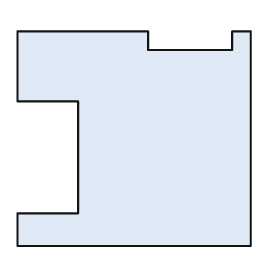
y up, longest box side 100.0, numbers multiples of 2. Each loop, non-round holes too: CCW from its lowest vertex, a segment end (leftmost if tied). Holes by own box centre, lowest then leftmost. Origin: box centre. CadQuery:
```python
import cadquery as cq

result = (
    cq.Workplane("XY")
    .moveTo(-50.0, -46.0)
    .lineTo(50.0, -46.0)
    .lineTo(50.0, 46.0)
    .lineTo(42.0, 46.0)
    .lineTo(42.0, 38.0)
    .lineTo(6.0, 38.0)
    .lineTo(6.0, 46.0)
    .lineTo(-50.0, 46.0)
    .lineTo(-50.0, 16.0)
    .lineTo(-24.0, 16.0)
    .lineTo(-24.0, -32.0)
    .lineTo(-50.0, -32.0)
    .close()
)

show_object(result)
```